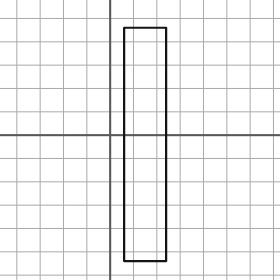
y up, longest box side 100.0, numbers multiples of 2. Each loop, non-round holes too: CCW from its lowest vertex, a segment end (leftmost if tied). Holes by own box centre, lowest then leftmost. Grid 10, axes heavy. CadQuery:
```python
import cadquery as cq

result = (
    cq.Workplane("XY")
    .moveTo(6.0, -54.0)
    .lineTo(24.0, -54.0)
    .lineTo(24.0, 46.0)
    .lineTo(6.0, 46.0)
    .close()
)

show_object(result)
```